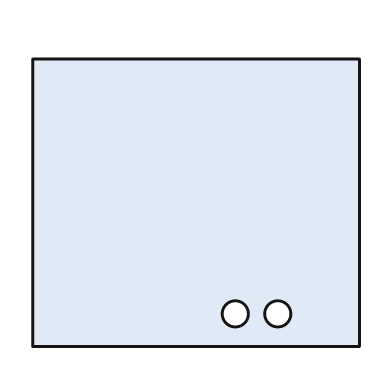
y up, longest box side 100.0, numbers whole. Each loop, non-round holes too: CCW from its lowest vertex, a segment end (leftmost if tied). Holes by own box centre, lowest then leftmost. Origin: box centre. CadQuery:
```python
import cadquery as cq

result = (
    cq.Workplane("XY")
    .moveTo(-50.0, -44.0)
    .lineTo(50.0, -44.0)
    .lineTo(50.0, 44.0)
    .lineTo(-50.0, 44.0)
    .close()
    .moveTo(12.0, -34.0)
    .circle(4.0)
    .moveTo(25.0, -34.0)
    .circle(4.0)
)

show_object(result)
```